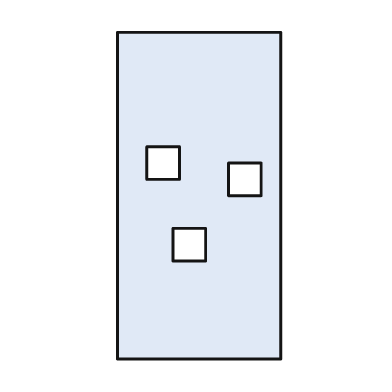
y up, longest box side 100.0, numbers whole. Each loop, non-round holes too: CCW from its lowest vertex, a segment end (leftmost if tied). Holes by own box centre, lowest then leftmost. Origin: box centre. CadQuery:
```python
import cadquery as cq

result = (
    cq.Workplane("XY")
    .moveTo(-25.0, -50.0)
    .lineTo(25.0, -50.0)
    .lineTo(25.0, 50.0)
    .lineTo(-25.0, 50.0)
    .close()
    .moveTo(-8.0, -20.0)
    .lineTo(2.0, -20.0)
    .lineTo(2.0, -10.0)
    .lineTo(-8.0, -10.0)
    .close()
    .moveTo(9.0, 0.0)
    .lineTo(19.0, 0.0)
    .lineTo(19.0, 10.0)
    .lineTo(9.0, 10.0)
    .close()
    .moveTo(-16.0, 5.0)
    .lineTo(-6.0, 5.0)
    .lineTo(-6.0, 15.0)
    .lineTo(-16.0, 15.0)
    .close()
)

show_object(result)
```